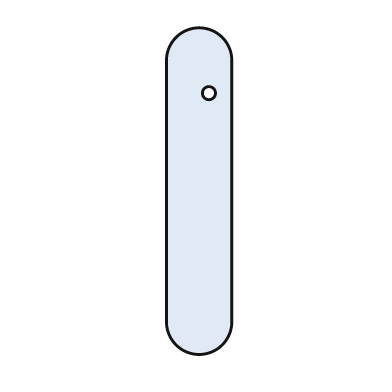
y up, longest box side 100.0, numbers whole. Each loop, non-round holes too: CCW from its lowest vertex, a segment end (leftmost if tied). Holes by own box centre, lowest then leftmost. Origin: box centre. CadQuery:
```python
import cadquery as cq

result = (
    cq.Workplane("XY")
    .moveTo(-10.0, -40.0)
    .threePointArc((0.0, -50.0), (10.0, -40.0))
    .lineTo(10.0, 40.0)
    .threePointArc((0.0, 50.0), (-10.0, 40.0))
    .close()
    .moveTo(3.0, 30.0)
    .circle(2.0)
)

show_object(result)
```